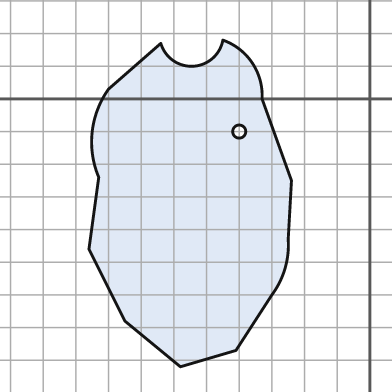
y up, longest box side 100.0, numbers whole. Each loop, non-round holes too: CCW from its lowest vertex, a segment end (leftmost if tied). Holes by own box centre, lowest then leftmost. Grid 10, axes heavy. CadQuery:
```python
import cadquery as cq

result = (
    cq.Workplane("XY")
    .moveTo(-58.0, -82.0)
    .lineTo(-41.0, -77.0)
    .lineTo(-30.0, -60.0)
    .threePointArc((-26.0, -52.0), (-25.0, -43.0))
    .lineTo(-24.0, -25.0)
    .lineTo(-33.0, 0.0)
    .threePointArc((-36.0, 11.0), (-45.0, 18.0))
    .threePointArc((-54.0, 10.0), (-64.0, 17.0))
    .lineTo(-80.0, 3.0)
    .threePointArc((-85.0, -10.0), (-83.0, -24.0))
    .lineTo(-86.0, -46.0)
    .lineTo(-75.0, -68.0)
    .close()
    .moveTo(-40.0, -10.0)
    .circle(2.0)
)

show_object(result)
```